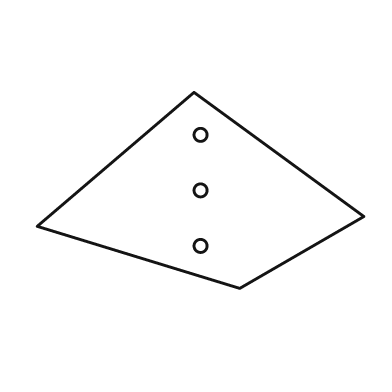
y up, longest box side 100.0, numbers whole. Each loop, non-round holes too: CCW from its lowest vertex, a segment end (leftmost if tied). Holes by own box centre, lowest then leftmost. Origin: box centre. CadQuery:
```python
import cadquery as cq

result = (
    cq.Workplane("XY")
    .moveTo(12.0, -30.0)
    .lineTo(50.0, -8.0)
    .lineTo(-2.0, 30.0)
    .lineTo(-50.0, -11.0)
    .close()
    .moveTo(0.0, -17.0)
    .circle(2.0)
    .moveTo(0.0, 0.0)
    .circle(2.0)
    .moveTo(0.0, 17.0)
    .circle(2.0)
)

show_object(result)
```